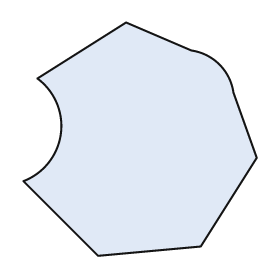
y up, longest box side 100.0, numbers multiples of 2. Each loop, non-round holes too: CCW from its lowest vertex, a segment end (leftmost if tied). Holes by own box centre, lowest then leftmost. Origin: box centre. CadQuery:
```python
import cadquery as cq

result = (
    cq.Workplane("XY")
    .moveTo(-18.0, -50.0)
    .lineTo(26.0, -46.0)
    .lineTo(50.0, -8.0)
    .lineTo(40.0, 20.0)
    .threePointArc((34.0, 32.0), (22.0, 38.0))
    .lineTo(-6.0, 50.0)
    .lineTo(-44.0, 26.0)
    .threePointArc((-34.0, 2.0), (-50.0, -18.0))
    .close()
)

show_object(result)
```